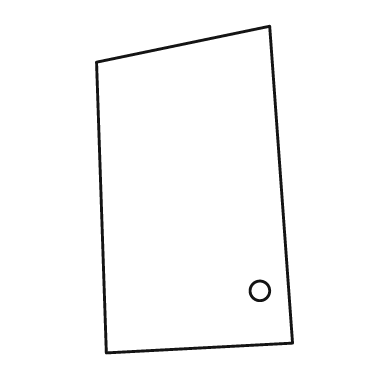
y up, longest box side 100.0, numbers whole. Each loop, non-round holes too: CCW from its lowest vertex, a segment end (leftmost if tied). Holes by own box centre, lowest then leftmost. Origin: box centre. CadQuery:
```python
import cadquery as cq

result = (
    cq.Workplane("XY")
    .moveTo(-27.0, -50.0)
    .lineTo(30.0, -47.0)
    .lineTo(23.0, 50.0)
    .lineTo(-30.0, 39.0)
    .close()
    .moveTo(20.0, -31.0)
    .circle(3.0)
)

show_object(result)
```